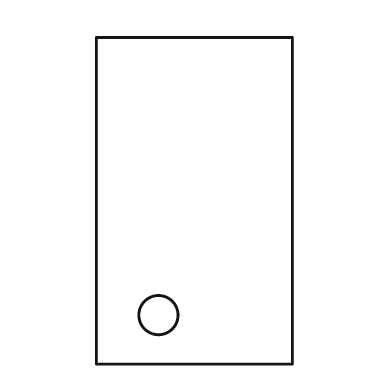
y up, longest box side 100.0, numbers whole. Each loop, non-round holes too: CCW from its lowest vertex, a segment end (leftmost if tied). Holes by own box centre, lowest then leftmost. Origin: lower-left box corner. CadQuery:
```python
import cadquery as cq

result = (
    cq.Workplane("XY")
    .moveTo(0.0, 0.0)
    .lineTo(60.0, 0.0)
    .lineTo(60.0, 100.0)
    .lineTo(0.0, 100.0)
    .close()
    .moveTo(19.0, 15.0)
    .circle(6.0)
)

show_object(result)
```